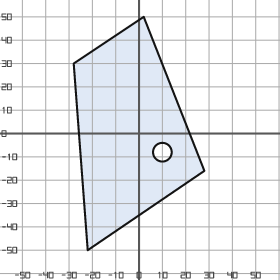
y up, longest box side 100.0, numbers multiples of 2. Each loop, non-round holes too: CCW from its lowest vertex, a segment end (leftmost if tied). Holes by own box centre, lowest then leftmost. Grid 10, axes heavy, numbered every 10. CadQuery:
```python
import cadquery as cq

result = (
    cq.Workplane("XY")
    .moveTo(-22.0, -50.0)
    .lineTo(28.0, -16.0)
    .lineTo(2.0, 50.0)
    .lineTo(-28.0, 30.0)
    .close()
    .moveTo(10.0, -8.0)
    .circle(4.0)
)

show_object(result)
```